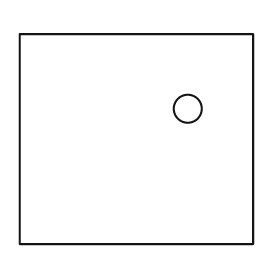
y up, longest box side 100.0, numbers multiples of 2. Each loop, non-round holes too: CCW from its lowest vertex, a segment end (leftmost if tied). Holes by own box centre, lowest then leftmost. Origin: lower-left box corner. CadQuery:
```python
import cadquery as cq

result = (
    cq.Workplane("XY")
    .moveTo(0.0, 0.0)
    .lineTo(100.0, 0.0)
    .lineTo(100.0, 90.0)
    .lineTo(0.0, 90.0)
    .close()
    .moveTo(72.0, 58.0)
    .circle(6.0)
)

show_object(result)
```